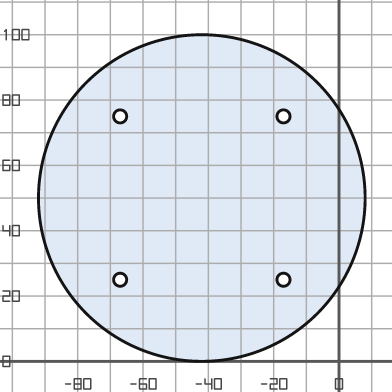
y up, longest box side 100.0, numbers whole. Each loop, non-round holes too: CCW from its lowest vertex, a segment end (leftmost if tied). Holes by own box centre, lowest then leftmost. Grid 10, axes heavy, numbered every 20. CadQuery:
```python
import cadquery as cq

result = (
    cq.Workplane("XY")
    .moveTo(-42.0, 50.0)
    .circle(50.0)
    .moveTo(-67.0, 25.0)
    .circle(2.0)
    .moveTo(-17.0, 25.0)
    .circle(2.0)
    .moveTo(-67.0, 75.0)
    .circle(2.0)
    .moveTo(-17.0, 75.0)
    .circle(2.0)
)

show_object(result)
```